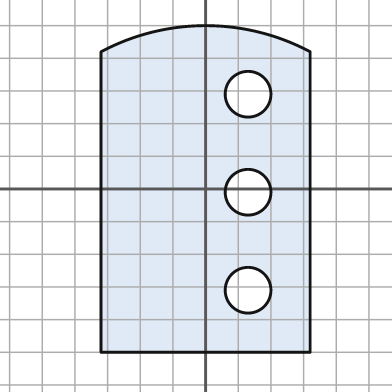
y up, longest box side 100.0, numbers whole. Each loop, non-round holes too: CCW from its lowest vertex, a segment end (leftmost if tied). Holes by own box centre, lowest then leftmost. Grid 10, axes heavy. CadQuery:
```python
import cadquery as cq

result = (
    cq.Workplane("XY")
    .moveTo(-32.0, -50.0)
    .lineTo(32.0, -50.0)
    .lineTo(32.0, 42.0)
    .threePointArc((0.0, 50.0), (-32.0, 42.0))
    .close()
    .moveTo(13.0, -31.0)
    .circle(7.0)
    .moveTo(13.0, -1.0)
    .circle(7.0)
    .moveTo(13.0, 29.0)
    .circle(7.0)
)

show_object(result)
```